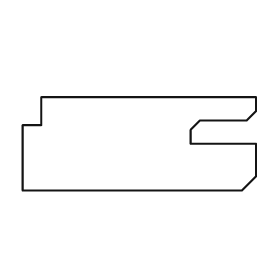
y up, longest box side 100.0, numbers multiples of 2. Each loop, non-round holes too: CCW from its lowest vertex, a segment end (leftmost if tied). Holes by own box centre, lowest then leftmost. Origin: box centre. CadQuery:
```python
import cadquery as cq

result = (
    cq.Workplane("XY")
    .moveTo(-50.0, -20.0)
    .lineTo(44.0, -20.0)
    .lineTo(50.0, -14.0)
    .lineTo(50.0, 0.0)
    .lineTo(22.0, 0.0)
    .lineTo(22.0, 6.0)
    .lineTo(26.0, 10.0)
    .lineTo(46.0, 10.0)
    .lineTo(50.0, 14.0)
    .lineTo(50.0, 20.0)
    .lineTo(-42.0, 20.0)
    .lineTo(-42.0, 8.0)
    .lineTo(-50.0, 8.0)
    .close()
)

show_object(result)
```